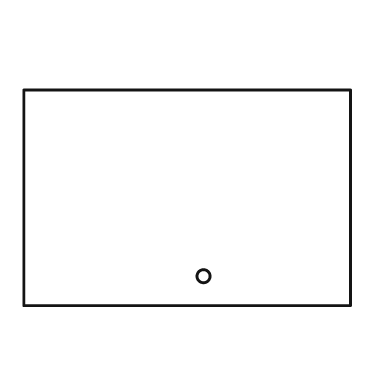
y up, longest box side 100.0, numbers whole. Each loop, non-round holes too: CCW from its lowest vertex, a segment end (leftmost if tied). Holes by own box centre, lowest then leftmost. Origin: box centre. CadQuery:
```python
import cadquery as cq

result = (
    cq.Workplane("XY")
    .moveTo(-50.0, -33.0)
    .lineTo(50.0, -33.0)
    .lineTo(50.0, 33.0)
    .lineTo(-50.0, 33.0)
    .close()
    .moveTo(5.0, -24.0)
    .circle(2.0)
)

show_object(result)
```